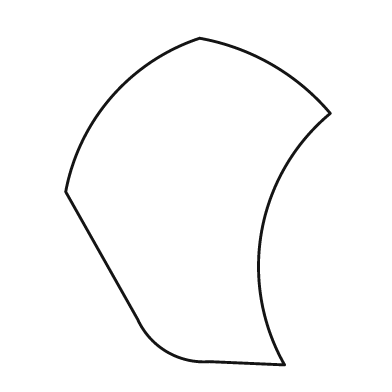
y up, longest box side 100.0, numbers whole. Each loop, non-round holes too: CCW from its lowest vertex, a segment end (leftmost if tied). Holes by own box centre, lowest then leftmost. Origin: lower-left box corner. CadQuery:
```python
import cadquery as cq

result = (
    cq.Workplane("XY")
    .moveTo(67.0, 0.0)
    .threePointArc((60.0, 41.0), (81.0, 77.0))
    .threePointArc((63.0, 92.0), (41.0, 100.0))
    .threePointArc((14.0, 82.0), (0.0, 53.0))
    .lineTo(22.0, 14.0)
    .threePointArc((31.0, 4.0), (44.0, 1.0))
    .close()
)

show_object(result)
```